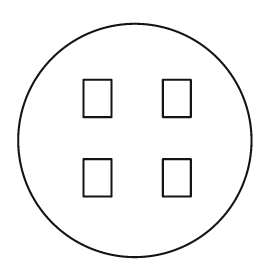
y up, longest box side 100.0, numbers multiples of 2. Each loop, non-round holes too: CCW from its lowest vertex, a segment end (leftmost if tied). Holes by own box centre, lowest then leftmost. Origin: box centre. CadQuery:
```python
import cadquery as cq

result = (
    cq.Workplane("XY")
    .moveTo(0.0, 0.0)
    .circle(50.0)
    .moveTo(-22.0, -24.0)
    .lineTo(-10.0, -24.0)
    .lineTo(-10.0, -8.0)
    .lineTo(-22.0, -8.0)
    .close()
    .moveTo(12.0, -24.0)
    .lineTo(24.0, -24.0)
    .lineTo(24.0, -8.0)
    .lineTo(12.0, -8.0)
    .close()
    .moveTo(-22.0, 10.0)
    .lineTo(-10.0, 10.0)
    .lineTo(-10.0, 26.0)
    .lineTo(-22.0, 26.0)
    .close()
    .moveTo(12.0, 10.0)
    .lineTo(24.0, 10.0)
    .lineTo(24.0, 26.0)
    .lineTo(12.0, 26.0)
    .close()
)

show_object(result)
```